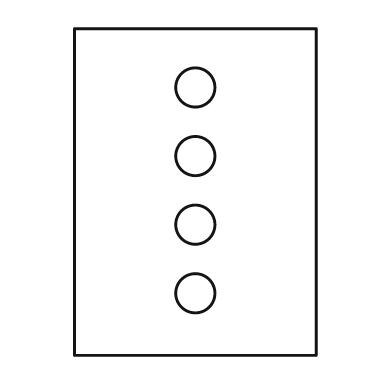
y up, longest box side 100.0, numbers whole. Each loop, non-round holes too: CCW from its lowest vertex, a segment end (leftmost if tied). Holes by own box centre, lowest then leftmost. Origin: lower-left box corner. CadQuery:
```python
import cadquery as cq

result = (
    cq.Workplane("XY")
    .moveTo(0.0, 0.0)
    .lineTo(74.0, 0.0)
    .lineTo(74.0, 100.0)
    .lineTo(0.0, 100.0)
    .close()
    .moveTo(37.0, 19.0)
    .circle(6.0)
    .moveTo(37.0, 40.0)
    .circle(6.0)
    .moveTo(37.0, 61.0)
    .circle(6.0)
    .moveTo(37.0, 82.0)
    .circle(6.0)
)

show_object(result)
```